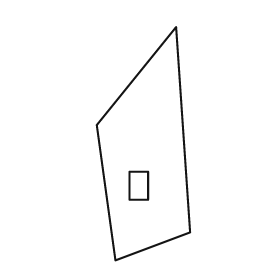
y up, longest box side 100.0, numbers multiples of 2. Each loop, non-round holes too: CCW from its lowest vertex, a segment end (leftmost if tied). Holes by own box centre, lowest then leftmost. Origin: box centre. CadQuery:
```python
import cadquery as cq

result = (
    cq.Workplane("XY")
    .moveTo(-12.0, -50.0)
    .lineTo(20.0, -38.0)
    .lineTo(14.0, 50.0)
    .lineTo(-20.0, 8.0)
    .close()
    .moveTo(-6.0, -24.0)
    .lineTo(2.0, -24.0)
    .lineTo(2.0, -12.0)
    .lineTo(-6.0, -12.0)
    .close()
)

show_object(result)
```